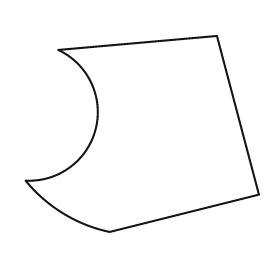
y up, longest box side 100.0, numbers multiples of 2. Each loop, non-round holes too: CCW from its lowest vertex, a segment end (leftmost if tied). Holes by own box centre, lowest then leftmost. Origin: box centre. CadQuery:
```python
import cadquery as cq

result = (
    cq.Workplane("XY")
    .moveTo(-14.0, -42.0)
    .lineTo(50.0, -26.0)
    .lineTo(32.0, 42.0)
    .lineTo(-36.0, 36.0)
    .threePointArc((-20.0, 2.0), (-50.0, -20.0))
    .threePointArc((-34.0, -34.0), (-14.0, -42.0))
    .close()
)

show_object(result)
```